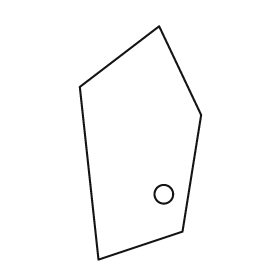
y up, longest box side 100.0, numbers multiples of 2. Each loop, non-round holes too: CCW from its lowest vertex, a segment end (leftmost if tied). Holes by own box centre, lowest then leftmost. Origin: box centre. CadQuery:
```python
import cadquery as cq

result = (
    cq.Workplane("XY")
    .moveTo(-18.0, -50.0)
    .lineTo(18.0, -38.0)
    .lineTo(26.0, 12.0)
    .lineTo(8.0, 50.0)
    .lineTo(-26.0, 24.0)
    .close()
    .moveTo(10.0, -22.0)
    .circle(4.0)
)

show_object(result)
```